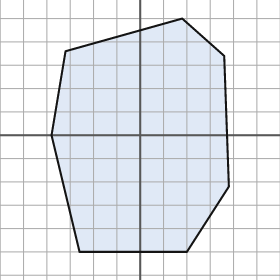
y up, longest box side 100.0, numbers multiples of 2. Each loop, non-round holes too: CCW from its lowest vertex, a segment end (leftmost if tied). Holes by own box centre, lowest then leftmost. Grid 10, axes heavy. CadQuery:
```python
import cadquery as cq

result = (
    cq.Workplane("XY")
    .moveTo(-26.0, -50.0)
    .lineTo(20.0, -50.0)
    .lineTo(38.0, -22.0)
    .lineTo(36.0, 34.0)
    .lineTo(18.0, 50.0)
    .lineTo(-32.0, 36.0)
    .lineTo(-38.0, 0.0)
    .close()
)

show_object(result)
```